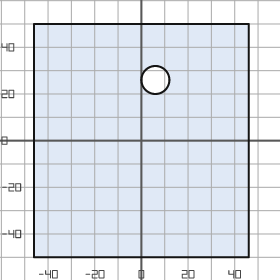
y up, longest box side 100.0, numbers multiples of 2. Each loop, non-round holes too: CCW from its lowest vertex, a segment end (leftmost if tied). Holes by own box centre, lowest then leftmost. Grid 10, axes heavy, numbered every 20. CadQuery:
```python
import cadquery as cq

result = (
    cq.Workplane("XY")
    .moveTo(-46.0, -50.0)
    .lineTo(46.0, -50.0)
    .lineTo(46.0, 50.0)
    .lineTo(-46.0, 50.0)
    .close()
    .moveTo(6.0, 26.0)
    .circle(6.0)
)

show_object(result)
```